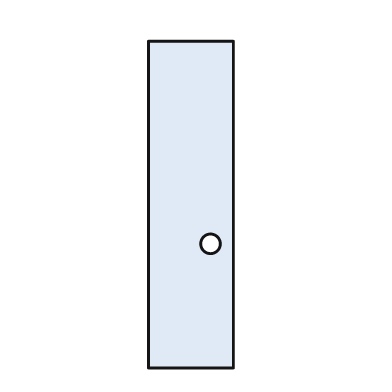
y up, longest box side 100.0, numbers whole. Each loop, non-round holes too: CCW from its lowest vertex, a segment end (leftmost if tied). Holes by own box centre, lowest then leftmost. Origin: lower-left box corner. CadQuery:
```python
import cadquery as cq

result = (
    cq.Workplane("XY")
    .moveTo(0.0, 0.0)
    .lineTo(26.0, 0.0)
    .lineTo(26.0, 100.0)
    .lineTo(0.0, 100.0)
    .close()
    .moveTo(19.0, 38.0)
    .circle(3.0)
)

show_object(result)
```